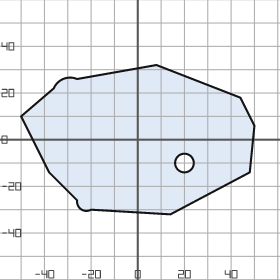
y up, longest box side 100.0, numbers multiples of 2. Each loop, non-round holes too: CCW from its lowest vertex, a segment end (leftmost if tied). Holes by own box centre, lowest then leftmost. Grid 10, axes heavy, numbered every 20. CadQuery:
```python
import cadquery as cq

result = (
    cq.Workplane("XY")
    .moveTo(14.0, -32.0)
    .lineTo(48.0, -14.0)
    .lineTo(50.0, 6.0)
    .lineTo(44.0, 18.0)
    .lineTo(8.0, 32.0)
    .lineTo(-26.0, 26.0)
    .threePointArc((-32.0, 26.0), (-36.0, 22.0))
    .lineTo(-50.0, 10.0)
    .lineTo(-38.0, -14.0)
    .lineTo(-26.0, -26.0)
    .threePointArc((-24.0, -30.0), (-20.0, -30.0))
    .close()
    .moveTo(20.0, -10.0)
    .circle(4.0)
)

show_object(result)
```